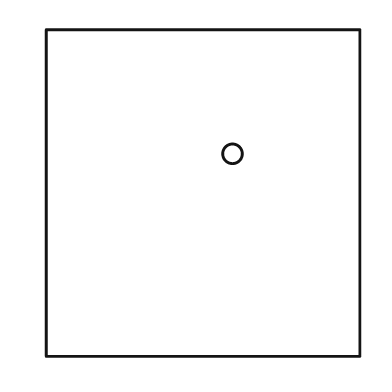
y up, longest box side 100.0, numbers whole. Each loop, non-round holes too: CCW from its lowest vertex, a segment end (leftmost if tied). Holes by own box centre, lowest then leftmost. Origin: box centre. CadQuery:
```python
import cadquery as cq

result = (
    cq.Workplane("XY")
    .moveTo(-48.0, -50.0)
    .lineTo(48.0, -50.0)
    .lineTo(48.0, 50.0)
    .lineTo(-48.0, 50.0)
    .close()
    .moveTo(9.0, 12.0)
    .circle(3.0)
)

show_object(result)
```